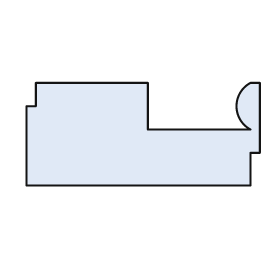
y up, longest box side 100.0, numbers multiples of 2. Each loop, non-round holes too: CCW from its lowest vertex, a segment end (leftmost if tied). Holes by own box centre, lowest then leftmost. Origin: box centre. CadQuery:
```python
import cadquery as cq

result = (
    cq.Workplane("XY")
    .moveTo(-50.0, -22.0)
    .lineTo(46.0, -22.0)
    .lineTo(46.0, -8.0)
    .lineTo(50.0, -8.0)
    .lineTo(50.0, 22.0)
    .lineTo(46.0, 22.0)
    .threePointArc((40.0, 12.0), (46.0, 2.0))
    .lineTo(2.0, 2.0)
    .lineTo(2.0, 22.0)
    .lineTo(-46.0, 22.0)
    .lineTo(-46.0, 12.0)
    .lineTo(-50.0, 12.0)
    .close()
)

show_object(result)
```